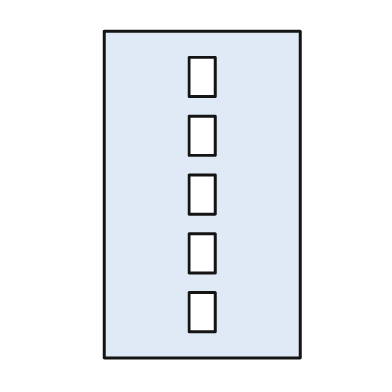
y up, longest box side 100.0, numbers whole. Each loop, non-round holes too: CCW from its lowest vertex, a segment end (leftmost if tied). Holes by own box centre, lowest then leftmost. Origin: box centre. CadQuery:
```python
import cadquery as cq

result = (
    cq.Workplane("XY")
    .moveTo(-30.0, -50.0)
    .lineTo(30.0, -50.0)
    .lineTo(30.0, 50.0)
    .lineTo(-30.0, 50.0)
    .close()
    .moveTo(-4.0, -42.0)
    .lineTo(4.0, -42.0)
    .lineTo(4.0, -30.0)
    .lineTo(-4.0, -30.0)
    .close()
    .moveTo(-4.0, -24.0)
    .lineTo(4.0, -24.0)
    .lineTo(4.0, -12.0)
    .lineTo(-4.0, -12.0)
    .close()
    .moveTo(-4.0, -6.0)
    .lineTo(4.0, -6.0)
    .lineTo(4.0, 6.0)
    .lineTo(-4.0, 6.0)
    .close()
    .moveTo(-4.0, 12.0)
    .lineTo(4.0, 12.0)
    .lineTo(4.0, 24.0)
    .lineTo(-4.0, 24.0)
    .close()
    .moveTo(-4.0, 30.0)
    .lineTo(4.0, 30.0)
    .lineTo(4.0, 42.0)
    .lineTo(-4.0, 42.0)
    .close()
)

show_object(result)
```